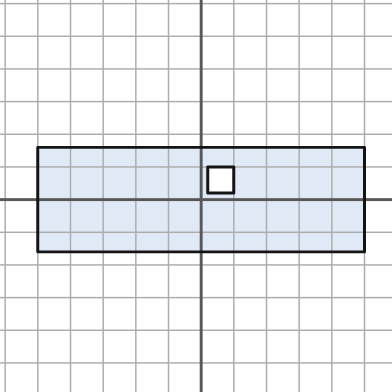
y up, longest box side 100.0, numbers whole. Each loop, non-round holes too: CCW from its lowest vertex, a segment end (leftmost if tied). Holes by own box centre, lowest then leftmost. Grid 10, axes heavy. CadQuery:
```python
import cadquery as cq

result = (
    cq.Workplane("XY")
    .moveTo(-50.0, -16.0)
    .lineTo(50.0, -16.0)
    .lineTo(50.0, 16.0)
    .lineTo(-50.0, 16.0)
    .close()
    .moveTo(2.0, 2.0)
    .lineTo(10.0, 2.0)
    .lineTo(10.0, 10.0)
    .lineTo(2.0, 10.0)
    .close()
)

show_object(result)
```